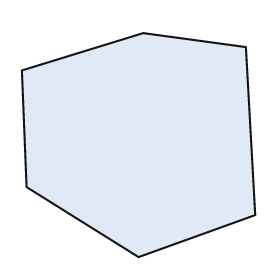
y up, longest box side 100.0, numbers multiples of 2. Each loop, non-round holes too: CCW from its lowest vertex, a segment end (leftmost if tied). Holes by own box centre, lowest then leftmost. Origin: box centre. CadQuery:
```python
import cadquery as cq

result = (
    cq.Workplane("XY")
    .moveTo(0.0, -48.0)
    .lineTo(50.0, -30.0)
    .lineTo(46.0, 42.0)
    .lineTo(2.0, 48.0)
    .lineTo(-50.0, 32.0)
    .lineTo(-48.0, -18.0)
    .close()
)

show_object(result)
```